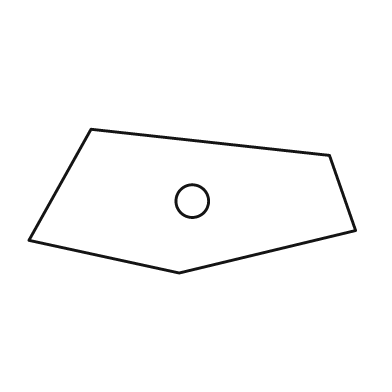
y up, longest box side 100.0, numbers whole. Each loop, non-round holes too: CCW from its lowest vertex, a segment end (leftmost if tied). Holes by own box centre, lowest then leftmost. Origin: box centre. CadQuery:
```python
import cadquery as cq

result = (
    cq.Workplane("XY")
    .moveTo(-4.0, -22.0)
    .lineTo(50.0, -9.0)
    .lineTo(42.0, 14.0)
    .lineTo(-31.0, 22.0)
    .lineTo(-50.0, -12.0)
    .close()
    .moveTo(0.0, 0.0)
    .circle(5.0)
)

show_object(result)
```